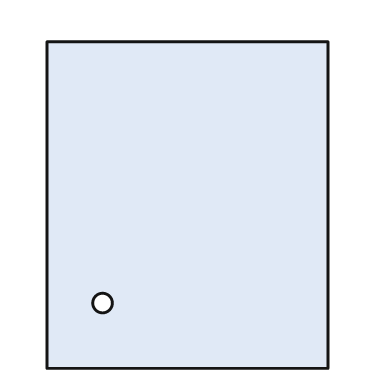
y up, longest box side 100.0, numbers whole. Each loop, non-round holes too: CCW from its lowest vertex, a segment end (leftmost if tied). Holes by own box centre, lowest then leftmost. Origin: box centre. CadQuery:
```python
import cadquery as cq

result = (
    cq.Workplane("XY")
    .moveTo(-43.0, -50.0)
    .lineTo(43.0, -50.0)
    .lineTo(43.0, 50.0)
    .lineTo(-43.0, 50.0)
    .close()
    .moveTo(-26.0, -30.0)
    .circle(3.0)
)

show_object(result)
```